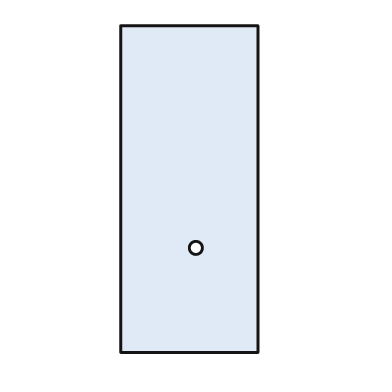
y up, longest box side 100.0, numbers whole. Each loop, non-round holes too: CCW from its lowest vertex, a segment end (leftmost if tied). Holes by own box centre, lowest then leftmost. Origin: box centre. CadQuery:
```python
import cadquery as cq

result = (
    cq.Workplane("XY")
    .moveTo(-21.0, -50.0)
    .lineTo(21.0, -50.0)
    .lineTo(21.0, 50.0)
    .lineTo(-21.0, 50.0)
    .close()
    .moveTo(2.0, -18.0)
    .circle(2.0)
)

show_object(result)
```